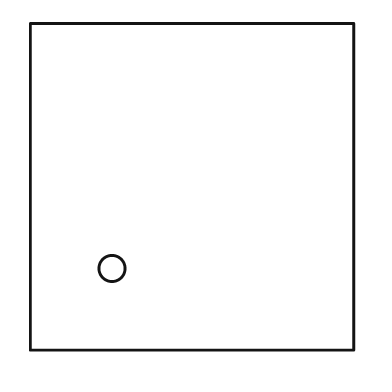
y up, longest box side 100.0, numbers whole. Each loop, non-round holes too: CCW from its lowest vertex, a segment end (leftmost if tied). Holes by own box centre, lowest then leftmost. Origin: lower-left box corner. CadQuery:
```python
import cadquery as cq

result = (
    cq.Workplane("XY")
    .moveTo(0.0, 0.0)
    .lineTo(99.0, 0.0)
    .lineTo(99.0, 100.0)
    .lineTo(0.0, 100.0)
    .close()
    .moveTo(25.0, 25.0)
    .circle(4.0)
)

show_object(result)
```